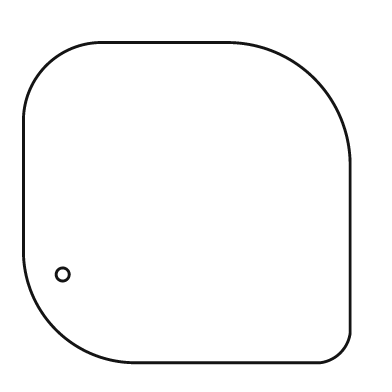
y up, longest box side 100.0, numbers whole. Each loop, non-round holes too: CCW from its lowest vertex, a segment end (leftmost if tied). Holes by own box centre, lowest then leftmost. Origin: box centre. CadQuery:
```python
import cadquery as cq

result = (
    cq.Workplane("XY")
    .moveTo(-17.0, -49.0)
    .lineTo(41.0, -49.0)
    .threePointArc((47.0, -46.0), (50.0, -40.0))
    .lineTo(50.0, 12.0)
    .threePointArc((39.0, 38.0), (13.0, 49.0))
    .lineTo(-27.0, 49.0)
    .threePointArc((-43.0, 42.0), (-50.0, 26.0))
    .lineTo(-50.0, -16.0)
    .threePointArc((-40.0, -39.0), (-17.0, -49.0))
    .close()
    .moveTo(-38.0, -22.0)
    .circle(2.0)
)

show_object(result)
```